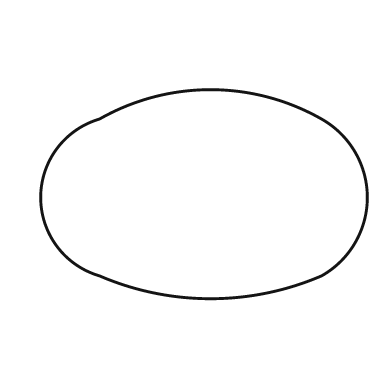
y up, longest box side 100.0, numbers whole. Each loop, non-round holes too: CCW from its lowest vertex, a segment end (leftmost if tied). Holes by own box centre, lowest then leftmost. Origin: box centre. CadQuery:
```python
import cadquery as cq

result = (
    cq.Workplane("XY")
    .moveTo(-32.0, -25.0)
    .threePointArc((2.0, -32.0), (36.0, -25.0))
    .threePointArc((50.0, -1.0), (36.0, 23.0))
    .threePointArc((2.0, 32.0), (-32.0, 23.0))
    .threePointArc((-50.0, -1.0), (-32.0, -25.0))
    .close()
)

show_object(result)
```